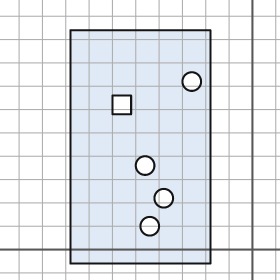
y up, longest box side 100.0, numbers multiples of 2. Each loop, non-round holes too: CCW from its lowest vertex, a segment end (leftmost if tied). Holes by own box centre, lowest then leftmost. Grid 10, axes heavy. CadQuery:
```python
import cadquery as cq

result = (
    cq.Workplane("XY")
    .moveTo(-78.0, -6.0)
    .lineTo(-18.0, -6.0)
    .lineTo(-18.0, 94.0)
    .lineTo(-78.0, 94.0)
    .close()
    .moveTo(-44.0, 10.0)
    .circle(4.0)
    .moveTo(-38.0, 22.0)
    .circle(4.0)
    .moveTo(-46.0, 36.0)
    .circle(4.0)
    .moveTo(-60.0, 58.0)
    .lineTo(-52.0, 58.0)
    .lineTo(-52.0, 66.0)
    .lineTo(-60.0, 66.0)
    .close()
    .moveTo(-26.0, 72.0)
    .circle(4.0)
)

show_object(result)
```